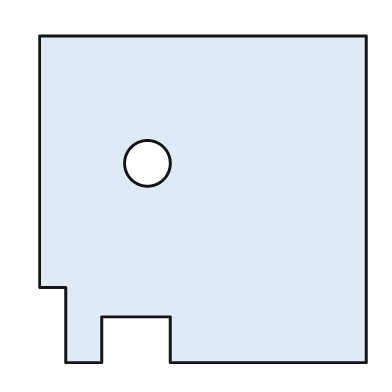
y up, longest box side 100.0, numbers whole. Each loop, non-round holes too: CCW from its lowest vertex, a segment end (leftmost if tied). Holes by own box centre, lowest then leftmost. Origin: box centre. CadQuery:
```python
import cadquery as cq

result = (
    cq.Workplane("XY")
    .moveTo(-42.0, -50.0)
    .lineTo(-31.0, -50.0)
    .lineTo(-31.0, -36.0)
    .lineTo(-10.0, -36.0)
    .lineTo(-10.0, -50.0)
    .lineTo(50.0, -50.0)
    .lineTo(50.0, 50.0)
    .lineTo(-50.0, 50.0)
    .lineTo(-50.0, -27.0)
    .lineTo(-42.0, -27.0)
    .close()
    .moveTo(-17.0, 11.0)
    .circle(7.0)
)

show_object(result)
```